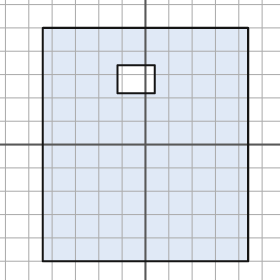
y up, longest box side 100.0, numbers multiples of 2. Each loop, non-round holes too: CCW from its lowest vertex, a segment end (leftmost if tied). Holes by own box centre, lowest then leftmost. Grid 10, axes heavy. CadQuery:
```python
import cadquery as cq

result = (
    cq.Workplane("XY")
    .moveTo(-44.0, -50.0)
    .lineTo(44.0, -50.0)
    .lineTo(44.0, 50.0)
    .lineTo(-44.0, 50.0)
    .close()
    .moveTo(-12.0, 22.0)
    .lineTo(4.0, 22.0)
    .lineTo(4.0, 34.0)
    .lineTo(-12.0, 34.0)
    .close()
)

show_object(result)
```